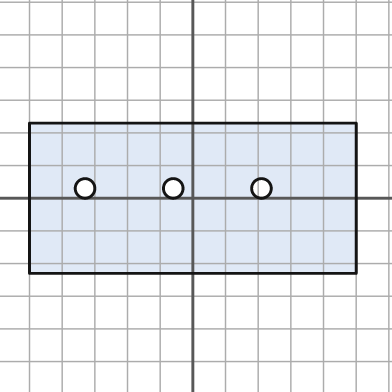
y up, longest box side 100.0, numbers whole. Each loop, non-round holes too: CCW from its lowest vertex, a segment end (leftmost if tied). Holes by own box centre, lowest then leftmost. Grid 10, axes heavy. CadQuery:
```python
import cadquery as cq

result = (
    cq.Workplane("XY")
    .moveTo(-50.0, -23.0)
    .lineTo(50.0, -23.0)
    .lineTo(50.0, 23.0)
    .lineTo(-50.0, 23.0)
    .close()
    .moveTo(-33.0, 3.0)
    .circle(3.0)
    .moveTo(-6.0, 3.0)
    .circle(3.0)
    .moveTo(21.0, 3.0)
    .circle(3.0)
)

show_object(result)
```